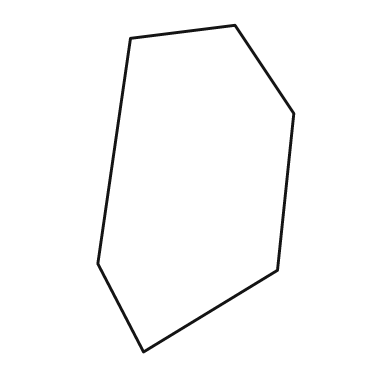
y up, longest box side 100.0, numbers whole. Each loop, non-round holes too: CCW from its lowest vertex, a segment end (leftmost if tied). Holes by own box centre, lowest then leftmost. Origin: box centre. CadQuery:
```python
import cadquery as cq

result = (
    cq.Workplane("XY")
    .moveTo(-16.0, -50.0)
    .lineTo(25.0, -25.0)
    .lineTo(30.0, 23.0)
    .lineTo(12.0, 50.0)
    .lineTo(-20.0, 46.0)
    .lineTo(-30.0, -23.0)
    .close()
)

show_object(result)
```